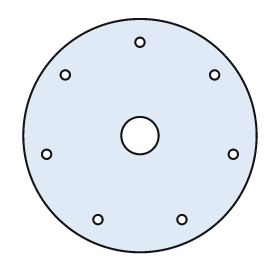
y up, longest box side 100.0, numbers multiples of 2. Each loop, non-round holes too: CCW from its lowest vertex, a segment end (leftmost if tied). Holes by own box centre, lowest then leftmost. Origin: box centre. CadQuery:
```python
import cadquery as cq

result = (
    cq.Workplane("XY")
    .moveTo(0.0, 0.0)
    .circle(50.0)
    .moveTo(-18.0, -36.0)
    .circle(2.0)
    .moveTo(18.0, -36.0)
    .circle(2.0)
    .moveTo(-40.0, -8.0)
    .circle(2.0)
    .moveTo(40.0, -8.0)
    .circle(2.0)
    .moveTo(0.0, 0.0)
    .circle(8.0)
    .moveTo(-32.0, 26.0)
    .circle(2.0)
    .moveTo(32.0, 26.0)
    .circle(2.0)
    .moveTo(0.0, 40.0)
    .circle(2.0)
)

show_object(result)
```